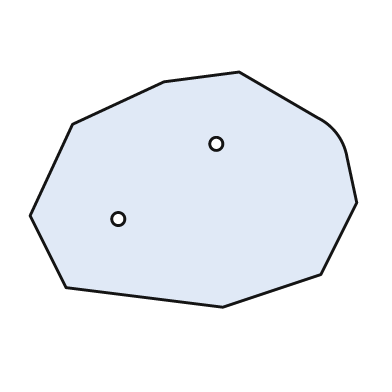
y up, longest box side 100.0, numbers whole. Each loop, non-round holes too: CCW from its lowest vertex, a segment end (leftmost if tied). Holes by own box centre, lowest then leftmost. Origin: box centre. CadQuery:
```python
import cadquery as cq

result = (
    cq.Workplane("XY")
    .moveTo(9.0, -36.0)
    .lineTo(39.0, -26.0)
    .lineTo(50.0, -4.0)
    .lineTo(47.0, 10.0)
    .threePointArc((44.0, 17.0), (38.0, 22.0))
    .lineTo(14.0, 36.0)
    .lineTo(-9.0, 33.0)
    .lineTo(-37.0, 20.0)
    .lineTo(-50.0, -8.0)
    .lineTo(-39.0, -30.0)
    .close()
    .moveTo(-23.0, -9.0)
    .circle(2.0)
    .moveTo(7.0, 14.0)
    .circle(2.0)
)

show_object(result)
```